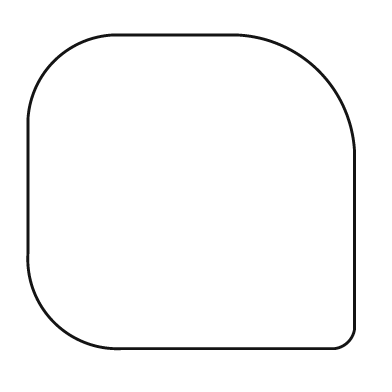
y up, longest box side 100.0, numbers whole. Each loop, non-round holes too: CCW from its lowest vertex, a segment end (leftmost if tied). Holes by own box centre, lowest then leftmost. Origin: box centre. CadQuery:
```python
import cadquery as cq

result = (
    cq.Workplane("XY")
    .moveTo(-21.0, -48.0)
    .lineTo(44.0, -48.0)
    .threePointArc((48.0, -46.0), (50.0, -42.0))
    .lineTo(50.0, 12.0)
    .threePointArc((39.0, 37.0), (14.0, 48.0))
    .lineTo(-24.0, 48.0)
    .threePointArc((-42.0, 40.0), (-50.0, 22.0))
    .lineTo(-50.0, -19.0)
    .threePointArc((-42.0, -40.0), (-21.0, -48.0))
    .close()
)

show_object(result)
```